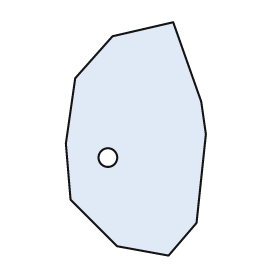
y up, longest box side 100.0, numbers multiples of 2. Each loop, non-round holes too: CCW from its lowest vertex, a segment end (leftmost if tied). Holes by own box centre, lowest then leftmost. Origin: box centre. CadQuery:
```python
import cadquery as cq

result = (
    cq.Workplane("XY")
    .moveTo(14.0, -50.0)
    .lineTo(26.0, -36.0)
    .lineTo(30.0, 2.0)
    .lineTo(28.0, 16.0)
    .lineTo(16.0, 50.0)
    .lineTo(-10.0, 44.0)
    .lineTo(-26.0, 26.0)
    .lineTo(-30.0, -2.0)
    .lineTo(-28.0, -26.0)
    .lineTo(-8.0, -46.0)
    .close()
    .moveTo(-12.0, -8.0)
    .circle(4.0)
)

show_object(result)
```